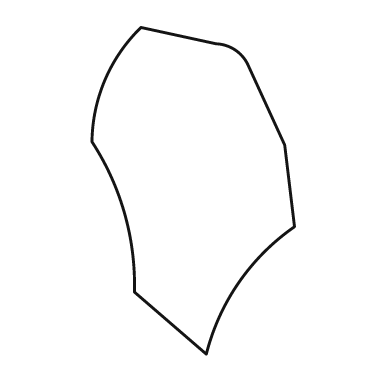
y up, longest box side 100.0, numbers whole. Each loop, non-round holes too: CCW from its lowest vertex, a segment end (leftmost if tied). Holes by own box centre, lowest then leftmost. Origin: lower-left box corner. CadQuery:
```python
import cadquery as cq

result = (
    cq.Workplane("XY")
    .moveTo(35.0, 0.0)
    .threePointArc((45.0, 22.0), (62.0, 39.0))
    .lineTo(59.0, 64.0)
    .lineTo(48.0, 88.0)
    .threePointArc((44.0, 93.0), (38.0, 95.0))
    .lineTo(15.0, 100.0)
    .threePointArc((4.0, 84.0), (0.0, 65.0))
    .threePointArc((10.0, 43.0), (13.0, 19.0))
    .close()
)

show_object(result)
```